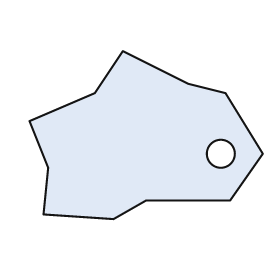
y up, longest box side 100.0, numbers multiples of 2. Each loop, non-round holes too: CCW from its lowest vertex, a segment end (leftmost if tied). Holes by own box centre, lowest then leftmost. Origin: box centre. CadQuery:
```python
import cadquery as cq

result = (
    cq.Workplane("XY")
    .moveTo(-14.0, -36.0)
    .lineTo(0.0, -28.0)
    .lineTo(36.0, -28.0)
    .lineTo(50.0, -8.0)
    .lineTo(34.0, 18.0)
    .lineTo(18.0, 22.0)
    .lineTo(-10.0, 36.0)
    .lineTo(-22.0, 18.0)
    .lineTo(-50.0, 6.0)
    .lineTo(-42.0, -14.0)
    .lineTo(-44.0, -34.0)
    .close()
    .moveTo(32.0, -8.0)
    .circle(6.0)
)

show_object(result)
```